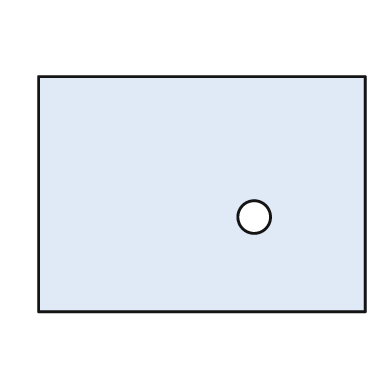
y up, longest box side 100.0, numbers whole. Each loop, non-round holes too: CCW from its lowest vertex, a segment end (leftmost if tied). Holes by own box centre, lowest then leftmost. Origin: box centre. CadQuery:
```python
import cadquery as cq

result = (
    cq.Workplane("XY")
    .moveTo(-50.0, -36.0)
    .lineTo(50.0, -36.0)
    .lineTo(50.0, 36.0)
    .lineTo(-50.0, 36.0)
    .close()
    .moveTo(16.0, -7.0)
    .circle(5.0)
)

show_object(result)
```